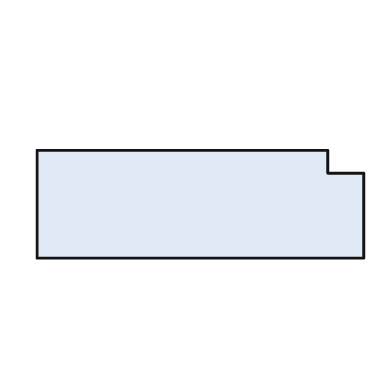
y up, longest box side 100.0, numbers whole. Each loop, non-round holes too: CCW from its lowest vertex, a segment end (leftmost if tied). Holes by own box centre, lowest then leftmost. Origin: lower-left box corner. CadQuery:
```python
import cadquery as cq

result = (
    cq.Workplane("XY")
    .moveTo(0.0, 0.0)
    .lineTo(100.0, 0.0)
    .lineTo(100.0, 26.0)
    .lineTo(89.0, 26.0)
    .lineTo(89.0, 33.0)
    .lineTo(0.0, 33.0)
    .close()
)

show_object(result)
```